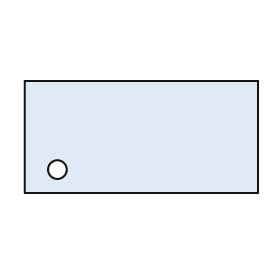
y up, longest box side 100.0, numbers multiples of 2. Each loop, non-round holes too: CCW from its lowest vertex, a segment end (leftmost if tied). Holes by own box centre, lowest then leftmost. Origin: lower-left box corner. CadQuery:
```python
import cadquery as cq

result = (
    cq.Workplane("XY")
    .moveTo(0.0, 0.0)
    .lineTo(100.0, 0.0)
    .lineTo(100.0, 48.0)
    .lineTo(0.0, 48.0)
    .close()
    .moveTo(14.0, 10.0)
    .circle(4.0)
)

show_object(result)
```